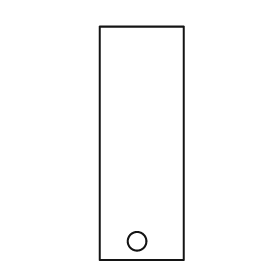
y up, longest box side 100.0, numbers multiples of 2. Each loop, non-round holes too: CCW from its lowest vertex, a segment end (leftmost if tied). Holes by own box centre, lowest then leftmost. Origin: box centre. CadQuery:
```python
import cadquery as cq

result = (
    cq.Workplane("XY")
    .moveTo(-18.0, -50.0)
    .lineTo(18.0, -50.0)
    .lineTo(18.0, 50.0)
    .lineTo(-18.0, 50.0)
    .close()
    .moveTo(-2.0, -42.0)
    .circle(4.0)
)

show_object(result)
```